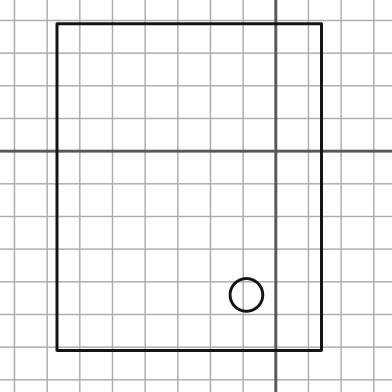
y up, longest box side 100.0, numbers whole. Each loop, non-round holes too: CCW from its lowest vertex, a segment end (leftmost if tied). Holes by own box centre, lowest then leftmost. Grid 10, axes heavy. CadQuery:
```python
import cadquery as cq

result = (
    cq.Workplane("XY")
    .moveTo(-67.0, -61.0)
    .lineTo(14.0, -61.0)
    .lineTo(14.0, 39.0)
    .lineTo(-67.0, 39.0)
    .close()
    .moveTo(-9.0, -44.0)
    .circle(5.0)
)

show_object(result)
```